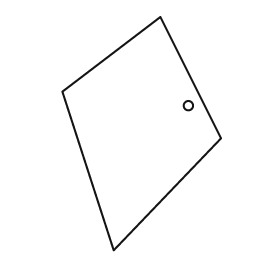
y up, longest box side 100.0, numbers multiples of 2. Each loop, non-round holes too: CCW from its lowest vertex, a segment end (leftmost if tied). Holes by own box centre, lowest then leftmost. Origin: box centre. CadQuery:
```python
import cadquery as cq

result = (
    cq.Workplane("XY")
    .moveTo(-12.0, -50.0)
    .lineTo(34.0, -2.0)
    .lineTo(8.0, 50.0)
    .lineTo(-34.0, 18.0)
    .close()
    .moveTo(20.0, 12.0)
    .circle(2.0)
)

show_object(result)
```